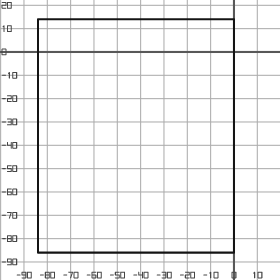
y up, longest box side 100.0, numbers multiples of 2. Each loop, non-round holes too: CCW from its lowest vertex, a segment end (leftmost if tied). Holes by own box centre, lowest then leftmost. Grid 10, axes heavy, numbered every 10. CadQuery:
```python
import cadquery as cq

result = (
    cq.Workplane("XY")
    .moveTo(-84.0, -86.0)
    .lineTo(0.0, -86.0)
    .lineTo(0.0, 14.0)
    .lineTo(-84.0, 14.0)
    .close()
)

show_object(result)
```